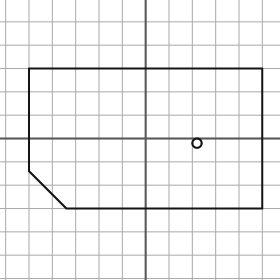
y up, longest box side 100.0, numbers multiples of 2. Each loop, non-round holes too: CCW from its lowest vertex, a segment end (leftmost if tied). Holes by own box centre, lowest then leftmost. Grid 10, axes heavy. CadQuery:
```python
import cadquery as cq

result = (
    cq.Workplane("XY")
    .moveTo(-34.0, -30.0)
    .lineTo(50.0, -30.0)
    .lineTo(50.0, 30.0)
    .lineTo(-50.0, 30.0)
    .lineTo(-50.0, -14.0)
    .close()
    .moveTo(22.0, -2.0)
    .circle(2.0)
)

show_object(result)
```